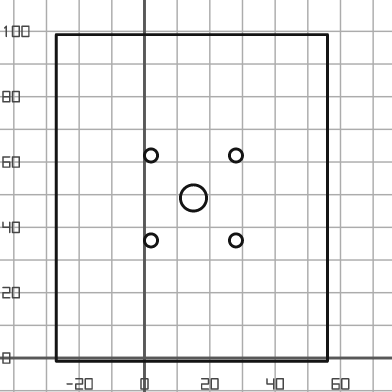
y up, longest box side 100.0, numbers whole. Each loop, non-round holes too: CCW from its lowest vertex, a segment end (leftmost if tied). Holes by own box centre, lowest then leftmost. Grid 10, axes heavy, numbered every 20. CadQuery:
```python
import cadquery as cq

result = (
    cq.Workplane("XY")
    .moveTo(-27.0, -1.0)
    .lineTo(56.0, -1.0)
    .lineTo(56.0, 99.0)
    .lineTo(-27.0, 99.0)
    .close()
    .moveTo(2.0, 36.0)
    .circle(2.0)
    .moveTo(28.0, 36.0)
    .circle(2.0)
    .moveTo(15.0, 49.0)
    .circle(4.0)
    .moveTo(2.0, 62.0)
    .circle(2.0)
    .moveTo(28.0, 62.0)
    .circle(2.0)
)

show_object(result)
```